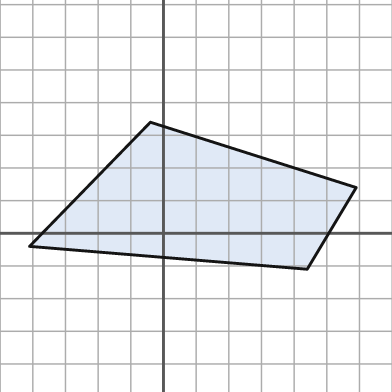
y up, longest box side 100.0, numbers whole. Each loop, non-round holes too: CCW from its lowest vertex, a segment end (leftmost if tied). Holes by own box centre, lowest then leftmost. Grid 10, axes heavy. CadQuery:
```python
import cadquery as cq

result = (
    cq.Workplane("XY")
    .moveTo(44.0, -11.0)
    .lineTo(59.0, 14.0)
    .lineTo(-4.0, 34.0)
    .lineTo(-41.0, -4.0)
    .close()
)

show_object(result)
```